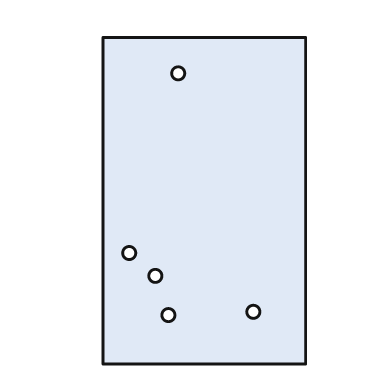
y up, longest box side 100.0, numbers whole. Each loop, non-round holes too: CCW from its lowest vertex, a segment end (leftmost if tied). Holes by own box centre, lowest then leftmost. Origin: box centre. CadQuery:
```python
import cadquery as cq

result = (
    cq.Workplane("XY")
    .moveTo(-31.0, -50.0)
    .lineTo(31.0, -50.0)
    .lineTo(31.0, 50.0)
    .lineTo(-31.0, 50.0)
    .close()
    .moveTo(-11.0, -35.0)
    .circle(2.0)
    .moveTo(15.0, -34.0)
    .circle(2.0)
    .moveTo(-15.0, -23.0)
    .circle(2.0)
    .moveTo(-23.0, -16.0)
    .circle(2.0)
    .moveTo(-8.0, 39.0)
    .circle(2.0)
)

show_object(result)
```